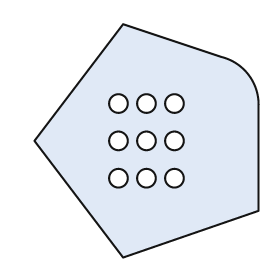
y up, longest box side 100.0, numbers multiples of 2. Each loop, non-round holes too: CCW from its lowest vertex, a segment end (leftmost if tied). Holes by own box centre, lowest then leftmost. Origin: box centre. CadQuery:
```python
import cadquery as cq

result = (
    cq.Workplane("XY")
    .moveTo(-10.0, -50.0)
    .lineTo(48.0, -30.0)
    .lineTo(48.0, 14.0)
    .threePointArc((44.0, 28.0), (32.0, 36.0))
    .lineTo(-10.0, 50.0)
    .lineTo(-48.0, 0.0)
    .close()
    .moveTo(-12.0, -16.0)
    .circle(4.0)
    .moveTo(0.0, -16.0)
    .circle(4.0)
    .moveTo(12.0, -16.0)
    .circle(4.0)
    .moveTo(-12.0, 0.0)
    .circle(4.0)
    .moveTo(0.0, 0.0)
    .circle(4.0)
    .moveTo(12.0, 0.0)
    .circle(4.0)
    .moveTo(-12.0, 16.0)
    .circle(4.0)
    .moveTo(0.0, 16.0)
    .circle(4.0)
    .moveTo(12.0, 16.0)
    .circle(4.0)
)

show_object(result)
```